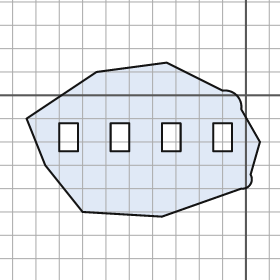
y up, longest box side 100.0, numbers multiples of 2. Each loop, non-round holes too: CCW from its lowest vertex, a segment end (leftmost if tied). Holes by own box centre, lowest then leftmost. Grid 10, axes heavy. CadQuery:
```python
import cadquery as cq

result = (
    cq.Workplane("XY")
    .moveTo(-36.0, -52.0)
    .lineTo(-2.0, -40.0)
    .threePointArc((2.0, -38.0), (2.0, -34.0))
    .lineTo(6.0, -20.0)
    .lineTo(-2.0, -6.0)
    .threePointArc((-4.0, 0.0), (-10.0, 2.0))
    .lineTo(-34.0, 14.0)
    .lineTo(-64.0, 10.0)
    .lineTo(-94.0, -10.0)
    .lineTo(-86.0, -30.0)
    .lineTo(-70.0, -50.0)
    .close()
    .moveTo(-80.0, -24.0)
    .lineTo(-72.0, -24.0)
    .lineTo(-72.0, -12.0)
    .lineTo(-80.0, -12.0)
    .close()
    .moveTo(-58.0, -24.0)
    .lineTo(-50.0, -24.0)
    .lineTo(-50.0, -12.0)
    .lineTo(-58.0, -12.0)
    .close()
    .moveTo(-36.0, -24.0)
    .lineTo(-28.0, -24.0)
    .lineTo(-28.0, -12.0)
    .lineTo(-36.0, -12.0)
    .close()
    .moveTo(-14.0, -24.0)
    .lineTo(-6.0, -24.0)
    .lineTo(-6.0, -12.0)
    .lineTo(-14.0, -12.0)
    .close()
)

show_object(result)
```